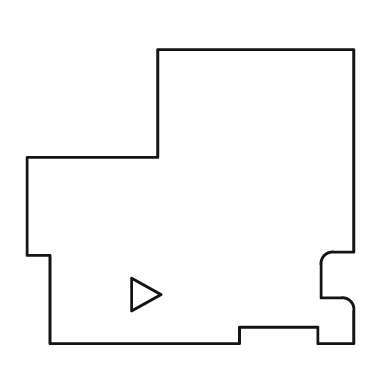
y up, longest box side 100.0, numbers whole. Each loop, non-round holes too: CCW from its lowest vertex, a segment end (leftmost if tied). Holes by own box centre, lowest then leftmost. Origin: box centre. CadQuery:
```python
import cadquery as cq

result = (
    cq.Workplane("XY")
    .moveTo(-43.0, -45.0)
    .lineTo(15.0, -45.0)
    .lineTo(15.0, -40.0)
    .lineTo(39.0, -40.0)
    .lineTo(39.0, -45.0)
    .lineTo(50.0, -45.0)
    .lineTo(50.0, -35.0)
    .threePointArc((49.0, -32.0), (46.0, -31.0))
    .lineTo(40.0, -31.0)
    .lineTo(40.0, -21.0)
    .threePointArc((41.0, -18.0), (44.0, -17.0))
    .lineTo(50.0, -17.0)
    .lineTo(50.0, 45.0)
    .lineTo(-10.0, 45.0)
    .lineTo(-10.0, 12.0)
    .lineTo(-50.0, 12.0)
    .lineTo(-50.0, -18.0)
    .lineTo(-43.0, -18.0)
    .close()
    .moveTo(-18.0, -35.0)
    .lineTo(-9.0, -30.0)
    .lineTo(-18.0, -25.0)
    .close()
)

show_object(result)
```